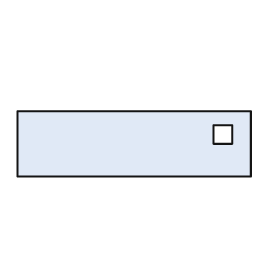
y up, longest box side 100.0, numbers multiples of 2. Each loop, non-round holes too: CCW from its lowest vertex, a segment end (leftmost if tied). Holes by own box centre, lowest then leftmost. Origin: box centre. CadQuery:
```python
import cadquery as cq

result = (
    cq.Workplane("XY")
    .moveTo(-50.0, -14.0)
    .lineTo(50.0, -14.0)
    .lineTo(50.0, 14.0)
    .lineTo(-50.0, 14.0)
    .close()
    .moveTo(34.0, 0.0)
    .lineTo(42.0, 0.0)
    .lineTo(42.0, 8.0)
    .lineTo(34.0, 8.0)
    .close()
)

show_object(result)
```